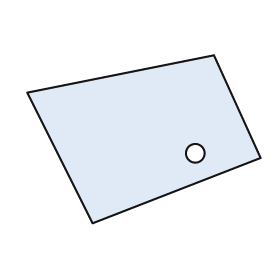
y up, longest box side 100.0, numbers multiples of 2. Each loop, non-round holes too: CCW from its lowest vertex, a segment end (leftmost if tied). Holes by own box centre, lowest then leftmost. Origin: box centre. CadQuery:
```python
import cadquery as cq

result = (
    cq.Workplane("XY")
    .moveTo(-22.0, -36.0)
    .lineTo(50.0, -8.0)
    .lineTo(30.0, 36.0)
    .lineTo(-50.0, 20.0)
    .close()
    .moveTo(22.0, -6.0)
    .circle(4.0)
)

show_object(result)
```